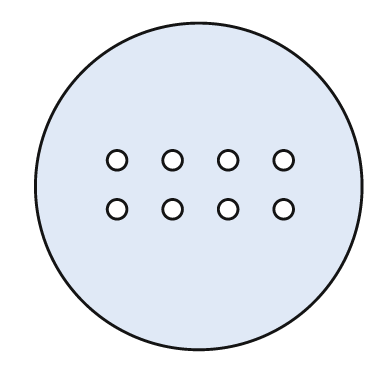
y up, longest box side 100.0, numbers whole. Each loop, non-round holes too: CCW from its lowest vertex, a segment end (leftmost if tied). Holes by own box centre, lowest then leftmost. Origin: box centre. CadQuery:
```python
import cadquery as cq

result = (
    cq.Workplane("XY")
    .moveTo(0.0, 0.0)
    .circle(50.0)
    .moveTo(-25.0, -7.0)
    .circle(3.0)
    .moveTo(-8.0, -7.0)
    .circle(3.0)
    .moveTo(9.0, -7.0)
    .circle(3.0)
    .moveTo(26.0, -7.0)
    .circle(3.0)
    .moveTo(-25.0, 8.0)
    .circle(3.0)
    .moveTo(-8.0, 8.0)
    .circle(3.0)
    .moveTo(9.0, 8.0)
    .circle(3.0)
    .moveTo(26.0, 8.0)
    .circle(3.0)
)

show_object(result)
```